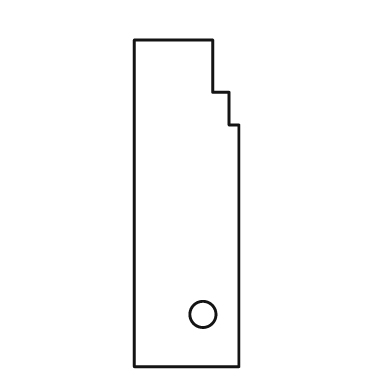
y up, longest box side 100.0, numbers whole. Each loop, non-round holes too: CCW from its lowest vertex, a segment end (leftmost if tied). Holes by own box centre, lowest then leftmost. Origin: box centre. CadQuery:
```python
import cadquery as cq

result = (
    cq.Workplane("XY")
    .moveTo(-16.0, -50.0)
    .lineTo(16.0, -50.0)
    .lineTo(16.0, 24.0)
    .lineTo(13.0, 24.0)
    .lineTo(13.0, 34.0)
    .lineTo(8.0, 34.0)
    .lineTo(8.0, 50.0)
    .lineTo(-16.0, 50.0)
    .close()
    .moveTo(5.0, -34.0)
    .circle(4.0)
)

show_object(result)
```